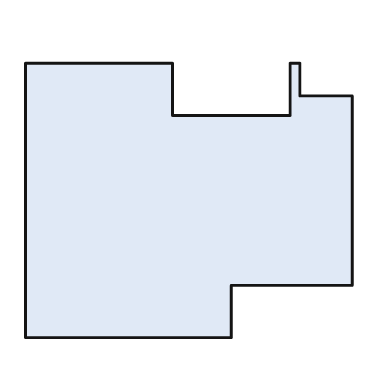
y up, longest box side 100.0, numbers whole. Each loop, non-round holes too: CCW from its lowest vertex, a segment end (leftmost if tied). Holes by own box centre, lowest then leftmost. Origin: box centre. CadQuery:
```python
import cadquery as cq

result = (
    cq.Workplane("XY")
    .moveTo(-50.0, -42.0)
    .lineTo(13.0, -42.0)
    .lineTo(13.0, -26.0)
    .lineTo(50.0, -26.0)
    .lineTo(50.0, 32.0)
    .lineTo(34.0, 32.0)
    .lineTo(34.0, 42.0)
    .lineTo(31.0, 42.0)
    .lineTo(31.0, 26.0)
    .lineTo(-5.0, 26.0)
    .lineTo(-5.0, 42.0)
    .lineTo(-50.0, 42.0)
    .close()
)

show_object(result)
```